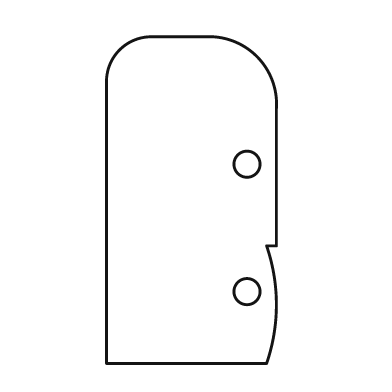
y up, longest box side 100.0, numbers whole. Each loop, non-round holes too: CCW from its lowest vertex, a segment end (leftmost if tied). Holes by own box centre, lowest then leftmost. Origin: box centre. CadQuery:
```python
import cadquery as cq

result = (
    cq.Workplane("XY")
    .moveTo(-26.0, -50.0)
    .lineTo(23.0, -50.0)
    .threePointArc((26.0, -32.0), (23.0, -14.0))
    .lineTo(26.0, -14.0)
    .lineTo(26.0, 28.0)
    .threePointArc((20.0, 44.0), (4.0, 50.0))
    .lineTo(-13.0, 50.0)
    .threePointArc((-22.0, 46.0), (-26.0, 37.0))
    .close()
    .moveTo(17.0, -28.0)
    .circle(4.0)
    .moveTo(17.0, 11.0)
    .circle(4.0)
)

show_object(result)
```